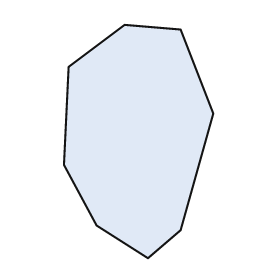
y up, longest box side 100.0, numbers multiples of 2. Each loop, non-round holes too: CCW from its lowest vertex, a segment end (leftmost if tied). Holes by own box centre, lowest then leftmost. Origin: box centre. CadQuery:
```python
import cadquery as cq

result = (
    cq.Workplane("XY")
    .moveTo(4.0, -50.0)
    .lineTo(18.0, -38.0)
    .lineTo(32.0, 12.0)
    .lineTo(18.0, 48.0)
    .lineTo(-6.0, 50.0)
    .lineTo(-30.0, 32.0)
    .lineTo(-32.0, -10.0)
    .lineTo(-18.0, -36.0)
    .close()
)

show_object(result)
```